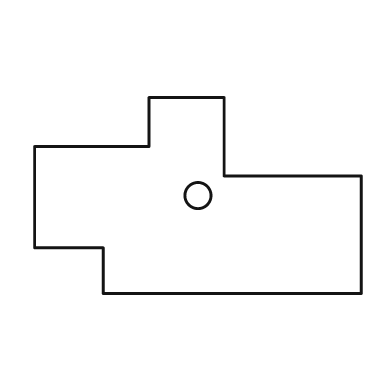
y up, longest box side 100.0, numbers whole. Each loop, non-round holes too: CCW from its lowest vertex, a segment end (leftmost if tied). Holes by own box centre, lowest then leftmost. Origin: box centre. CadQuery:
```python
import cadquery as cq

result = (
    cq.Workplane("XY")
    .moveTo(-29.0, -30.0)
    .lineTo(50.0, -30.0)
    .lineTo(50.0, 6.0)
    .lineTo(8.0, 6.0)
    .lineTo(8.0, 30.0)
    .lineTo(-15.0, 30.0)
    .lineTo(-15.0, 15.0)
    .lineTo(-50.0, 15.0)
    .lineTo(-50.0, -16.0)
    .lineTo(-29.0, -16.0)
    .close()
    .moveTo(0.0, 0.0)
    .circle(4.0)
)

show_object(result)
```